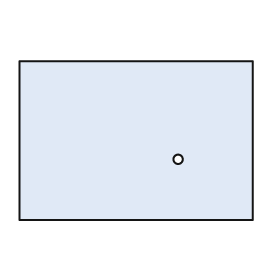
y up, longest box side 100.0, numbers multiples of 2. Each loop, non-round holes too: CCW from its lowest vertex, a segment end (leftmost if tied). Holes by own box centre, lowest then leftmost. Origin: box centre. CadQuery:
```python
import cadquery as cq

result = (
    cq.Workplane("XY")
    .moveTo(-50.0, -34.0)
    .lineTo(50.0, -34.0)
    .lineTo(50.0, 34.0)
    .lineTo(-50.0, 34.0)
    .close()
    .moveTo(18.0, -8.0)
    .circle(2.0)
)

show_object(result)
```